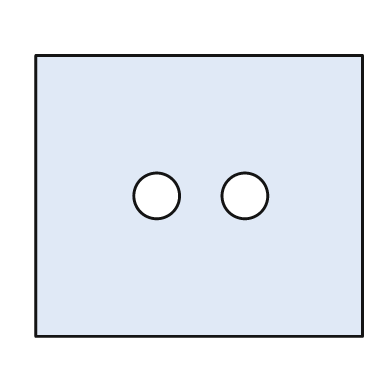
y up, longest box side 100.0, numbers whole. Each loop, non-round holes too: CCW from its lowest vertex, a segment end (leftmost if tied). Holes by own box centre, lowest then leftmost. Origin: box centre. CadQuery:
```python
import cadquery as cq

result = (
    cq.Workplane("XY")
    .moveTo(-50.0, -43.0)
    .lineTo(50.0, -43.0)
    .lineTo(50.0, 43.0)
    .lineTo(-50.0, 43.0)
    .close()
    .moveTo(-13.0, 0.0)
    .circle(7.0)
    .moveTo(14.0, 0.0)
    .circle(7.0)
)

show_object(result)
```